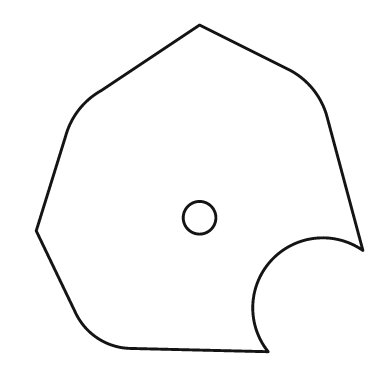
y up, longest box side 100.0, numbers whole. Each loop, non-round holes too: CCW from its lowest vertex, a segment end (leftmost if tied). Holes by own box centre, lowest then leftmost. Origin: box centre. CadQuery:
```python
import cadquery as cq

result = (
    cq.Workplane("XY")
    .moveTo(21.0, -50.0)
    .threePointArc((22.0, -22.0), (50.0, -19.0))
    .lineTo(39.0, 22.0)
    .threePointArc((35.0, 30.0), (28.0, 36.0))
    .lineTo(0.0, 50.0)
    .lineTo(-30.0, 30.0)
    .threePointArc((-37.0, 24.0), (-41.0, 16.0))
    .lineTo(-50.0, -13.0)
    .lineTo(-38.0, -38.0)
    .threePointArc((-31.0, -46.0), (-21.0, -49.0))
    .close()
    .moveTo(0.0, -9.0)
    .circle(5.0)
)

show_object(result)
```